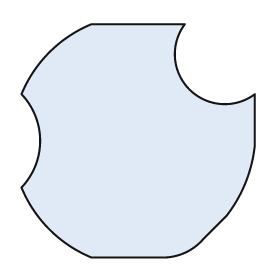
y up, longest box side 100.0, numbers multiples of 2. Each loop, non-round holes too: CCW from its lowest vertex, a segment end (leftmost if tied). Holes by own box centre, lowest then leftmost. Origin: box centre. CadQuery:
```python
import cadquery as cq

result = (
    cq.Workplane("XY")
    .moveTo(-20.0, -50.0)
    .lineTo(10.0, -50.0)
    .threePointArc((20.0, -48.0), (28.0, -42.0))
    .lineTo(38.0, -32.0)
    .threePointArc((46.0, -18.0), (50.0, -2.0))
    .lineTo(50.0, 20.0)
    .threePointArc((22.0, 22.0), (20.0, 50.0))
    .lineTo(-20.0, 50.0)
    .threePointArc((-38.0, 38.0), (-50.0, 20.0))
    .threePointArc((-42.0, 0.0), (-50.0, -20.0))
    .threePointArc((-38.0, -38.0), (-20.0, -50.0))
    .close()
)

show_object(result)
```